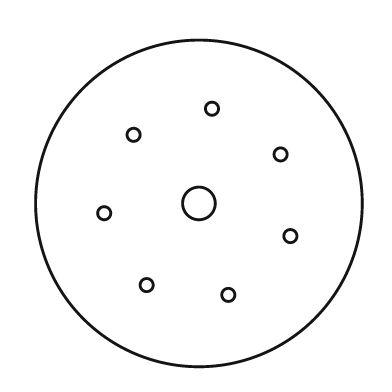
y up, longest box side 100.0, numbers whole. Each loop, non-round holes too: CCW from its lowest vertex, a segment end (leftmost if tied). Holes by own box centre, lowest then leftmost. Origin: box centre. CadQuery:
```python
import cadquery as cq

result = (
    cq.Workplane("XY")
    .moveTo(0.0, 0.0)
    .circle(50.0)
    .moveTo(9.0, -28.0)
    .circle(2.0)
    .moveTo(-16.0, -25.0)
    .circle(2.0)
    .moveTo(28.0, -10.0)
    .circle(2.0)
    .moveTo(-29.0, -3.0)
    .circle(2.0)
    .moveTo(0.0, 0.0)
    .circle(5.0)
    .moveTo(25.0, 15.0)
    .circle(2.0)
    .moveTo(-20.0, 21.0)
    .circle(2.0)
    .moveTo(4.0, 29.0)
    .circle(2.0)
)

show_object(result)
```